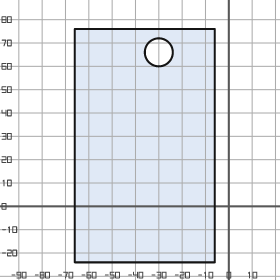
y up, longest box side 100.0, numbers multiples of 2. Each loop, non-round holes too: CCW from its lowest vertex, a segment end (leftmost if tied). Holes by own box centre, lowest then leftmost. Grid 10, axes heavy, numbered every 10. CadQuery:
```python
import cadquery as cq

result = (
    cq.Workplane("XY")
    .moveTo(-66.0, -24.0)
    .lineTo(-6.0, -24.0)
    .lineTo(-6.0, 76.0)
    .lineTo(-66.0, 76.0)
    .close()
    .moveTo(-30.0, 66.0)
    .circle(6.0)
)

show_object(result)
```